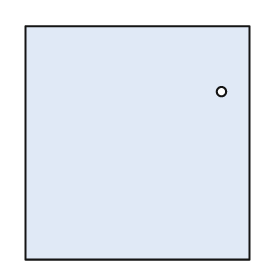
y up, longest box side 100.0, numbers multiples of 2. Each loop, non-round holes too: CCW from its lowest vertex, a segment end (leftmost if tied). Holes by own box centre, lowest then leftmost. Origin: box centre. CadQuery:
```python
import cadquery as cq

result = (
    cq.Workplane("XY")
    .moveTo(-48.0, -50.0)
    .lineTo(48.0, -50.0)
    .lineTo(48.0, 50.0)
    .lineTo(-48.0, 50.0)
    .close()
    .moveTo(36.0, 22.0)
    .circle(2.0)
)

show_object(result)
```